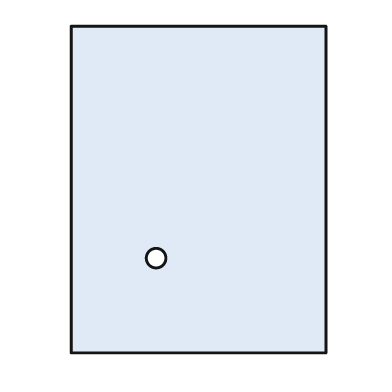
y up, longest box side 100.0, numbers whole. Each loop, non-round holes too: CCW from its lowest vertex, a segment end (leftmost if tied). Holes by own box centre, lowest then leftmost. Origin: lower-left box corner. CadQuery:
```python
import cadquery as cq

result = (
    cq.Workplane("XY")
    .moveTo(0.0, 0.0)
    .lineTo(78.0, 0.0)
    .lineTo(78.0, 100.0)
    .lineTo(0.0, 100.0)
    .close()
    .moveTo(26.0, 29.0)
    .circle(3.0)
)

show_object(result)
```